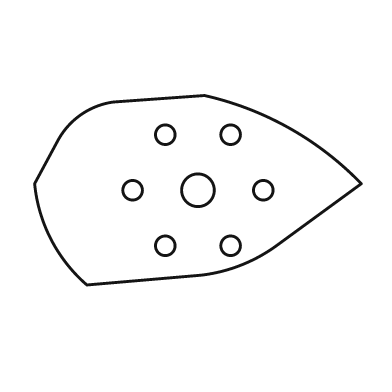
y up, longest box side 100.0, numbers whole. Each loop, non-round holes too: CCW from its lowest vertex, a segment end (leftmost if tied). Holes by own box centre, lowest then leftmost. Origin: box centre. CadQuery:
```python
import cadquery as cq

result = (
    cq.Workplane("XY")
    .moveTo(-34.0, -29.0)
    .lineTo(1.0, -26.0)
    .threePointArc((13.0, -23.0), (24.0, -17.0))
    .lineTo(50.0, 2.0)
    .threePointArc((28.0, 19.0), (2.0, 29.0))
    .lineTo(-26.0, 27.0)
    .threePointArc((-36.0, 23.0), (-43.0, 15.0))
    .lineTo(-50.0, 2.0)
    .threePointArc((-45.0, -15.0), (-34.0, -29.0))
    .close()
    .moveTo(-10.0, -17.0)
    .circle(3.0)
    .moveTo(10.0, -17.0)
    .circle(3.0)
    .moveTo(-20.0, 0.0)
    .circle(3.0)
    .moveTo(0.0, 0.0)
    .circle(5.0)
    .moveTo(20.0, 0.0)
    .circle(3.0)
    .moveTo(-10.0, 17.0)
    .circle(3.0)
    .moveTo(10.0, 17.0)
    .circle(3.0)
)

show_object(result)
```